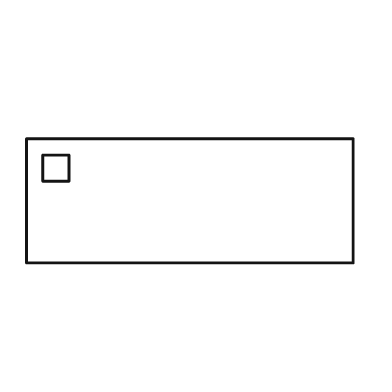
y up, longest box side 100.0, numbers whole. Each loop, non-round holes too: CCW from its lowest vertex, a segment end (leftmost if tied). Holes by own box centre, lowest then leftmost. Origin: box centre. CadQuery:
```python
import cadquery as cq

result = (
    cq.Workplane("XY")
    .moveTo(-50.0, -19.0)
    .lineTo(50.0, -19.0)
    .lineTo(50.0, 19.0)
    .lineTo(-50.0, 19.0)
    .close()
    .moveTo(-45.0, 6.0)
    .lineTo(-37.0, 6.0)
    .lineTo(-37.0, 14.0)
    .lineTo(-45.0, 14.0)
    .close()
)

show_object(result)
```